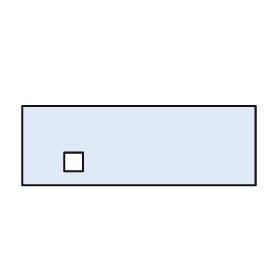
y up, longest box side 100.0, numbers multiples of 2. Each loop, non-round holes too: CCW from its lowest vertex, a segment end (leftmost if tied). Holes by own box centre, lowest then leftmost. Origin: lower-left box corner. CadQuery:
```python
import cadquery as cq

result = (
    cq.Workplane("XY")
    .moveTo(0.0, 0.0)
    .lineTo(100.0, 0.0)
    .lineTo(100.0, 34.0)
    .lineTo(0.0, 34.0)
    .close()
    .moveTo(18.0, 6.0)
    .lineTo(26.0, 6.0)
    .lineTo(26.0, 14.0)
    .lineTo(18.0, 14.0)
    .close()
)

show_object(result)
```